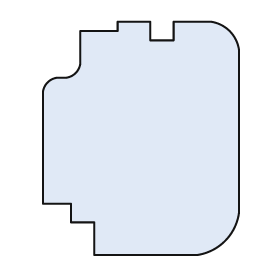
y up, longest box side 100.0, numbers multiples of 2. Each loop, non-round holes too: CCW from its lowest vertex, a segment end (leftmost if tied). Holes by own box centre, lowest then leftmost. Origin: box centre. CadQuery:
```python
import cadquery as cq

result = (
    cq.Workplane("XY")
    .moveTo(-20.0, -50.0)
    .lineTo(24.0, -50.0)
    .threePointArc((36.0, -44.0), (42.0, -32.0))
    .lineTo(42.0, 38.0)
    .threePointArc((38.0, 46.0), (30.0, 50.0))
    .lineTo(14.0, 50.0)
    .lineTo(14.0, 42.0)
    .lineTo(4.0, 42.0)
    .lineTo(4.0, 50.0)
    .lineTo(-10.0, 50.0)
    .lineTo(-10.0, 46.0)
    .lineTo(-26.0, 46.0)
    .lineTo(-26.0, 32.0)
    .threePointArc((-28.0, 28.0), (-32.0, 26.0))
    .lineTo(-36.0, 26.0)
    .threePointArc((-40.0, 24.0), (-42.0, 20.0))
    .lineTo(-42.0, -28.0)
    .lineTo(-30.0, -28.0)
    .lineTo(-30.0, -36.0)
    .lineTo(-20.0, -36.0)
    .close()
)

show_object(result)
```